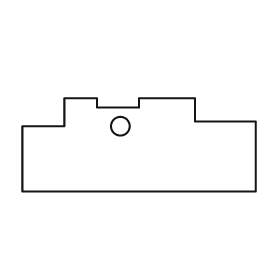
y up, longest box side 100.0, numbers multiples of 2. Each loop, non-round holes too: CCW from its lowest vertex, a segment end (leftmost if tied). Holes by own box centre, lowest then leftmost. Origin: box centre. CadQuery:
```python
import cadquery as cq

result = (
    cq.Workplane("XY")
    .moveTo(-50.0, -20.0)
    .lineTo(50.0, -20.0)
    .lineTo(50.0, 10.0)
    .lineTo(24.0, 10.0)
    .lineTo(24.0, 20.0)
    .lineTo(0.0, 20.0)
    .lineTo(0.0, 16.0)
    .lineTo(-18.0, 16.0)
    .lineTo(-18.0, 20.0)
    .lineTo(-32.0, 20.0)
    .lineTo(-32.0, 8.0)
    .lineTo(-50.0, 8.0)
    .close()
    .moveTo(-8.0, 8.0)
    .circle(4.0)
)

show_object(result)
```